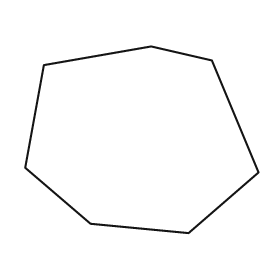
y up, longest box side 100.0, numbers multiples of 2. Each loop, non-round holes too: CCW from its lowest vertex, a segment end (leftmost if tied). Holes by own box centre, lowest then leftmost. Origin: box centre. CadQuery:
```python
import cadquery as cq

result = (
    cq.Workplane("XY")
    .moveTo(20.0, -40.0)
    .lineTo(50.0, -14.0)
    .lineTo(30.0, 34.0)
    .lineTo(4.0, 40.0)
    .lineTo(-42.0, 32.0)
    .lineTo(-50.0, -12.0)
    .lineTo(-22.0, -36.0)
    .close()
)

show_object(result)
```